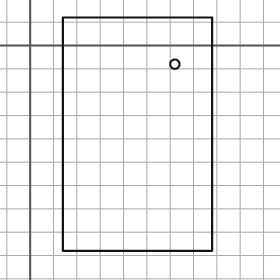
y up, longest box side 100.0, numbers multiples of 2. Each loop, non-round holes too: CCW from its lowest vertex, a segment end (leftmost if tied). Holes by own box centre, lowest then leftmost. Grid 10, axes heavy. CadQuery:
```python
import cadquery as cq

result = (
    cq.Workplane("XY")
    .moveTo(14.0, -88.0)
    .lineTo(78.0, -88.0)
    .lineTo(78.0, 12.0)
    .lineTo(14.0, 12.0)
    .close()
    .moveTo(62.0, -8.0)
    .circle(2.0)
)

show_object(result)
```